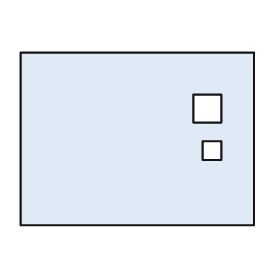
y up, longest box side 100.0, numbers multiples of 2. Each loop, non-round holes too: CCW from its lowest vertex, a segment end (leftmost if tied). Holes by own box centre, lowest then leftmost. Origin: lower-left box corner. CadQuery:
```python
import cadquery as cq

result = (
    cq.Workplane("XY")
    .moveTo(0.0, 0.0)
    .lineTo(100.0, 0.0)
    .lineTo(100.0, 74.0)
    .lineTo(0.0, 74.0)
    .close()
    .moveTo(78.0, 28.0)
    .lineTo(86.0, 28.0)
    .lineTo(86.0, 36.0)
    .lineTo(78.0, 36.0)
    .close()
    .moveTo(74.0, 44.0)
    .lineTo(86.0, 44.0)
    .lineTo(86.0, 56.0)
    .lineTo(74.0, 56.0)
    .close()
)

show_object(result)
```